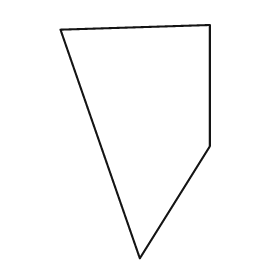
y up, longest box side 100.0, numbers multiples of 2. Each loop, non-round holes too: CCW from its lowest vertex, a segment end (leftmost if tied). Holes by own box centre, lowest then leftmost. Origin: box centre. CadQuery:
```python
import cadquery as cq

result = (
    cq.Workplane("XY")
    .moveTo(2.0, -50.0)
    .lineTo(32.0, -2.0)
    .lineTo(32.0, 50.0)
    .lineTo(-32.0, 48.0)
    .close()
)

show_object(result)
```